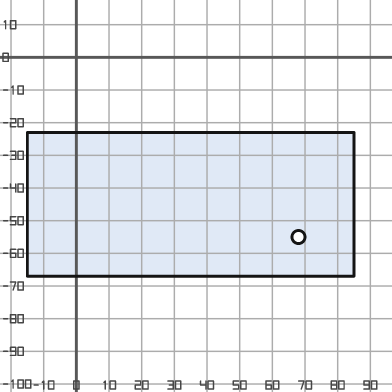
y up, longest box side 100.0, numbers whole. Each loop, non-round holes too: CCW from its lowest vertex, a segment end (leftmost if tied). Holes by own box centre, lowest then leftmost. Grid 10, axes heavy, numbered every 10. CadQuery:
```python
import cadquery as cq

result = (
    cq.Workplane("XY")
    .moveTo(-15.0, -67.0)
    .lineTo(85.0, -67.0)
    .lineTo(85.0, -23.0)
    .lineTo(-15.0, -23.0)
    .close()
    .moveTo(68.0, -55.0)
    .circle(2.0)
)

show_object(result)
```